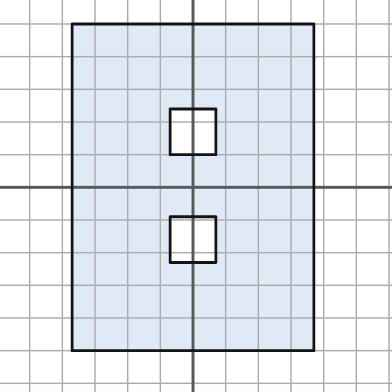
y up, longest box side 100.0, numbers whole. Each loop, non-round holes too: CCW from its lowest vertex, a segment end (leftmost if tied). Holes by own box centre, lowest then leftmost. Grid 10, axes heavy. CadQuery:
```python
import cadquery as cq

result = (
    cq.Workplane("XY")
    .moveTo(-37.0, -50.0)
    .lineTo(37.0, -50.0)
    .lineTo(37.0, 50.0)
    .lineTo(-37.0, 50.0)
    .close()
    .moveTo(-7.0, -23.0)
    .lineTo(7.0, -23.0)
    .lineTo(7.0, -9.0)
    .lineTo(-7.0, -9.0)
    .close()
    .moveTo(-7.0, 10.0)
    .lineTo(7.0, 10.0)
    .lineTo(7.0, 24.0)
    .lineTo(-7.0, 24.0)
    .close()
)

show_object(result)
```